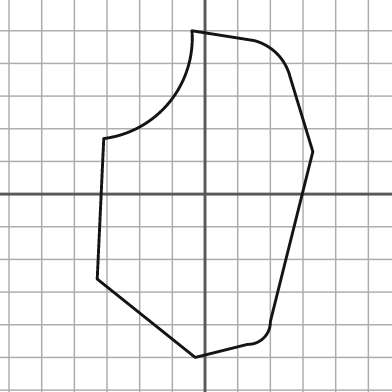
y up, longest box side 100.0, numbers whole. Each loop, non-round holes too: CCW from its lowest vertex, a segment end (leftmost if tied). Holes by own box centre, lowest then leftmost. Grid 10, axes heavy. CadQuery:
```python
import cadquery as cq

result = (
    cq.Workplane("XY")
    .moveTo(-3.0, -50.0)
    .lineTo(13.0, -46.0)
    .threePointArc((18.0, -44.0), (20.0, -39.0))
    .lineTo(33.0, 13.0)
    .lineTo(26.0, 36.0)
    .threePointArc((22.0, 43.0), (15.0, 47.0))
    .lineTo(-4.0, 50.0)
    .threePointArc((-11.0, 28.0), (-31.0, 17.0))
    .lineTo(-33.0, -26.0)
    .close()
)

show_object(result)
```